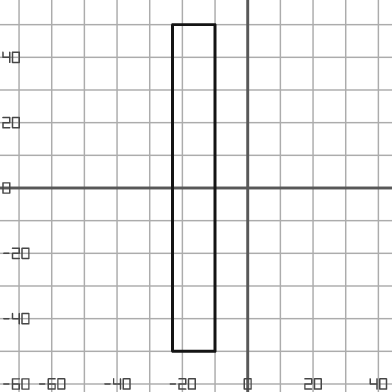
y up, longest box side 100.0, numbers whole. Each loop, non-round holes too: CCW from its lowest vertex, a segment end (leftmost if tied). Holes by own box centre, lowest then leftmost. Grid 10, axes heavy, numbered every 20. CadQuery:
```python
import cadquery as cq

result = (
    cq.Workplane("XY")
    .moveTo(-23.0, -50.0)
    .lineTo(-10.0, -50.0)
    .lineTo(-10.0, 50.0)
    .lineTo(-23.0, 50.0)
    .close()
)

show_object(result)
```